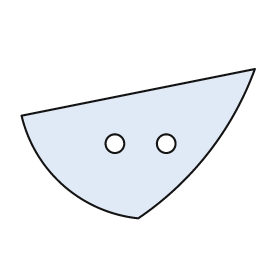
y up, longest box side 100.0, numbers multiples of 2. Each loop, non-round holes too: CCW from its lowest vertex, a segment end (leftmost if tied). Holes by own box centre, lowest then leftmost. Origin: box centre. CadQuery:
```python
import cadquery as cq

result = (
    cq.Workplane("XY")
    .moveTo(0.0, -32.0)
    .threePointArc((30.0, -4.0), (50.0, 32.0))
    .lineTo(-50.0, 12.0)
    .threePointArc((-32.0, -18.0), (0.0, -32.0))
    .close()
    .moveTo(-10.0, 0.0)
    .circle(4.0)
    .moveTo(12.0, 0.0)
    .circle(4.0)
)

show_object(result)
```